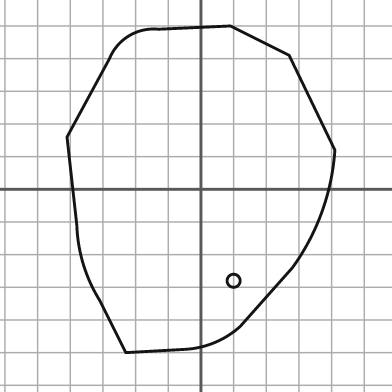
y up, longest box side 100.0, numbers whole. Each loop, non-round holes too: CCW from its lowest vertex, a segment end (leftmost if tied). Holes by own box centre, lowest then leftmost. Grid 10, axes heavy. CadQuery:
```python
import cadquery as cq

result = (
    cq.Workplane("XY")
    .moveTo(-23.0, -50.0)
    .lineTo(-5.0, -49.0)
    .threePointArc((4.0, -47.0), (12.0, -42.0))
    .lineTo(28.0, -24.0)
    .threePointArc((37.0, -7.0), (41.0, 12.0))
    .lineTo(27.0, 41.0)
    .lineTo(9.0, 50.0)
    .lineTo(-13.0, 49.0)
    .threePointArc((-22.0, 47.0), (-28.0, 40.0))
    .lineTo(-41.0, 16.0)
    .lineTo(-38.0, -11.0)
    .threePointArc((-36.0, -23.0), (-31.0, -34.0))
    .close()
    .moveTo(10.0, -28.0)
    .circle(2.0)
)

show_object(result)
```